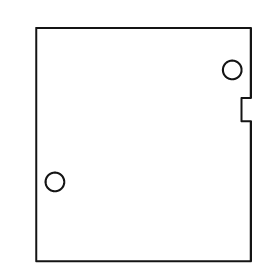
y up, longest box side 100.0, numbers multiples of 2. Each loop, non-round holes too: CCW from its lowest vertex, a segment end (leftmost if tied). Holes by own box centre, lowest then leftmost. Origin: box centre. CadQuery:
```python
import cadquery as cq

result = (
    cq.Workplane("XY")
    .moveTo(-46.0, -50.0)
    .lineTo(46.0, -50.0)
    .lineTo(46.0, 10.0)
    .lineTo(42.0, 10.0)
    .lineTo(42.0, 20.0)
    .lineTo(46.0, 20.0)
    .lineTo(46.0, 50.0)
    .lineTo(-46.0, 50.0)
    .close()
    .moveTo(-38.0, -16.0)
    .circle(4.0)
    .moveTo(38.0, 32.0)
    .circle(4.0)
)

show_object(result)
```